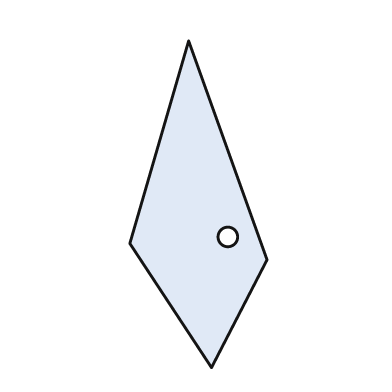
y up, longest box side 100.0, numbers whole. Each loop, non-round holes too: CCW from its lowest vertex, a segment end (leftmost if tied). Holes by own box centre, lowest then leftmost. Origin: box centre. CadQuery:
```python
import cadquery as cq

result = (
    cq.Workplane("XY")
    .moveTo(4.0, -50.0)
    .lineTo(21.0, -17.0)
    .lineTo(-3.0, 50.0)
    .lineTo(-21.0, -12.0)
    .close()
    .moveTo(9.0, -10.0)
    .circle(3.0)
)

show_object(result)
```